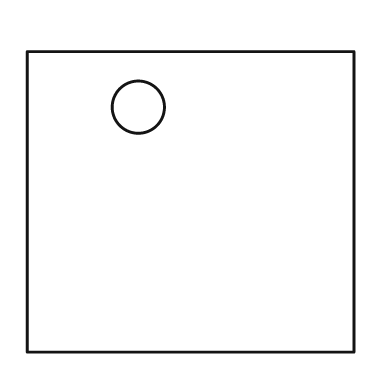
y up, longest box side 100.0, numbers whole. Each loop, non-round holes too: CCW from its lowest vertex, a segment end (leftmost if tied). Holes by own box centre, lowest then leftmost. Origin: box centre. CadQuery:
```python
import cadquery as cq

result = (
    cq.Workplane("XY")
    .moveTo(-50.0, -46.0)
    .lineTo(50.0, -46.0)
    .lineTo(50.0, 46.0)
    .lineTo(-50.0, 46.0)
    .close()
    .moveTo(-16.0, 29.0)
    .circle(8.0)
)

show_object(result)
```